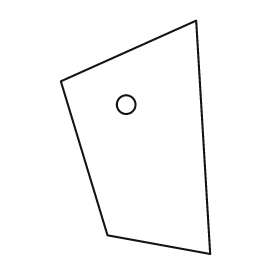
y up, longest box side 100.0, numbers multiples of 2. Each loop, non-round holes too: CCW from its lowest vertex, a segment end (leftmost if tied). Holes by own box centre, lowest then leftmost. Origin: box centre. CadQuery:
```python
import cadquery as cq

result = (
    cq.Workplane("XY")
    .moveTo(32.0, -50.0)
    .lineTo(26.0, 50.0)
    .lineTo(-32.0, 24.0)
    .lineTo(-12.0, -42.0)
    .close()
    .moveTo(-4.0, 14.0)
    .circle(4.0)
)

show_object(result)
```